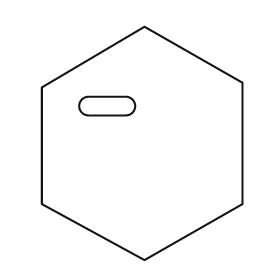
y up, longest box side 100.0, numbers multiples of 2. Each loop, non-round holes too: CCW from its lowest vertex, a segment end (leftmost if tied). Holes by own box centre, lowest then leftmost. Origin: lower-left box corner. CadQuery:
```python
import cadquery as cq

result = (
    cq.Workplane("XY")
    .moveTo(44.0, 0.0)
    .lineTo(86.0, 24.0)
    .lineTo(86.0, 76.0)
    .lineTo(44.0, 100.0)
    .lineTo(0.0, 74.0)
    .lineTo(0.0, 24.0)
    .close()
    .moveTo(20.0, 62.0)
    .lineTo(36.0, 62.0)
    .threePointArc((40.0, 66.0), (36.0, 70.0))
    .lineTo(20.0, 70.0)
    .threePointArc((16.0, 66.0), (20.0, 62.0))
    .close()
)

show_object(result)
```